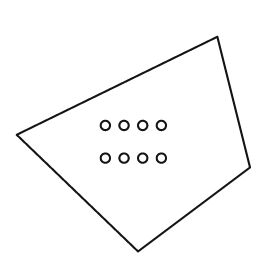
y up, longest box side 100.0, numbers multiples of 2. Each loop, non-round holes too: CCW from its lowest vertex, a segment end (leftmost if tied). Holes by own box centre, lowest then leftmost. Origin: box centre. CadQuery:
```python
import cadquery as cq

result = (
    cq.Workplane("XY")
    .moveTo(2.0, -46.0)
    .lineTo(50.0, -10.0)
    .lineTo(36.0, 46.0)
    .lineTo(-50.0, 4.0)
    .close()
    .moveTo(-12.0, -6.0)
    .circle(2.0)
    .moveTo(-4.0, -6.0)
    .circle(2.0)
    .moveTo(4.0, -6.0)
    .circle(2.0)
    .moveTo(12.0, -6.0)
    .circle(2.0)
    .moveTo(-12.0, 8.0)
    .circle(2.0)
    .moveTo(-4.0, 8.0)
    .circle(2.0)
    .moveTo(4.0, 8.0)
    .circle(2.0)
    .moveTo(12.0, 8.0)
    .circle(2.0)
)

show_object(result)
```